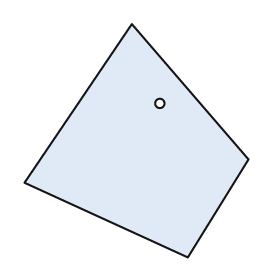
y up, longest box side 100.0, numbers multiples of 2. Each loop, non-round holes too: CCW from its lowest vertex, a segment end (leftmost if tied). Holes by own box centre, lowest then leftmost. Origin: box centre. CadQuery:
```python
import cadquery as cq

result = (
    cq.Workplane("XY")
    .moveTo(22.0, -50.0)
    .lineTo(48.0, -8.0)
    .lineTo(-2.0, 50.0)
    .lineTo(-48.0, -18.0)
    .close()
    .moveTo(10.0, 16.0)
    .circle(2.0)
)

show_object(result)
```